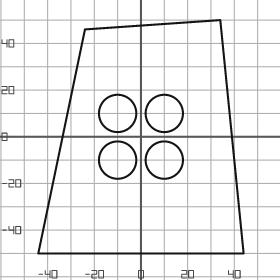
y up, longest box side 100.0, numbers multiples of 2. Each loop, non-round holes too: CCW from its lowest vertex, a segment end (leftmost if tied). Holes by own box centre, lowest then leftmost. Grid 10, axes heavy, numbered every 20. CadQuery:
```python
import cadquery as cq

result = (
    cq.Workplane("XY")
    .moveTo(-44.0, -50.0)
    .lineTo(44.0, -50.0)
    .lineTo(34.0, 50.0)
    .lineTo(-24.0, 46.0)
    .close()
    .moveTo(-10.0, -10.0)
    .circle(8.0)
    .moveTo(10.0, -10.0)
    .circle(8.0)
    .moveTo(-10.0, 10.0)
    .circle(8.0)
    .moveTo(10.0, 10.0)
    .circle(8.0)
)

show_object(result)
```